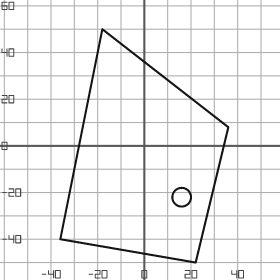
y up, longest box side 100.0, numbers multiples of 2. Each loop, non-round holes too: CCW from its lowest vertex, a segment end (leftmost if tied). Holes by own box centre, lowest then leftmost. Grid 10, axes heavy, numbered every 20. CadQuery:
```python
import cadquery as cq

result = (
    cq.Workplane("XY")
    .moveTo(22.0, -50.0)
    .lineTo(36.0, 8.0)
    .lineTo(-18.0, 50.0)
    .lineTo(-36.0, -40.0)
    .close()
    .moveTo(16.0, -22.0)
    .circle(4.0)
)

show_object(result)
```